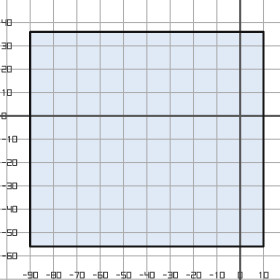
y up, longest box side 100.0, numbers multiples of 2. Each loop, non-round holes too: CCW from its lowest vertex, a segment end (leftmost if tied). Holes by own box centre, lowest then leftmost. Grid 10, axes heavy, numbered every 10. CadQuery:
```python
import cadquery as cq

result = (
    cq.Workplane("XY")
    .moveTo(-90.0, -56.0)
    .lineTo(10.0, -56.0)
    .lineTo(10.0, 36.0)
    .lineTo(-90.0, 36.0)
    .close()
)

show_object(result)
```